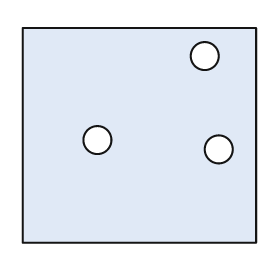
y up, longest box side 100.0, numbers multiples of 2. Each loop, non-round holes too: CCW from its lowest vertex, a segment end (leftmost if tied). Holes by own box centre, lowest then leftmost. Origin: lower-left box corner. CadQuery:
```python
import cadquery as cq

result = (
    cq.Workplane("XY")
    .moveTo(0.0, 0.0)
    .lineTo(100.0, 0.0)
    .lineTo(100.0, 92.0)
    .lineTo(0.0, 92.0)
    .close()
    .moveTo(84.0, 40.0)
    .circle(6.0)
    .moveTo(32.0, 44.0)
    .circle(6.0)
    .moveTo(78.0, 80.0)
    .circle(6.0)
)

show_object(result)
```